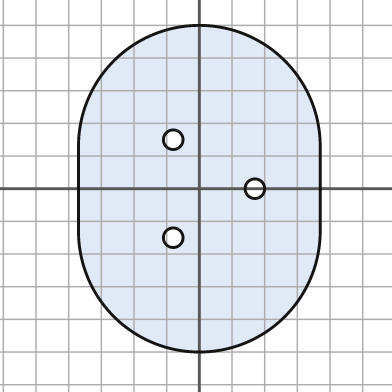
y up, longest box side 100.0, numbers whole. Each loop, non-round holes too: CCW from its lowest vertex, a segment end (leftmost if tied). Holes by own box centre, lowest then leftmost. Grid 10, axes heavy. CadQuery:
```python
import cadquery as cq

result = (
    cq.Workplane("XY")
    .moveTo(-37.0, -13.0)
    .threePointArc((0.0, -50.0), (37.0, -13.0))
    .lineTo(37.0, 13.0)
    .threePointArc((0.0, 50.0), (-37.0, 13.0))
    .close()
    .moveTo(-8.0, -15.0)
    .circle(3.0)
    .moveTo(17.0, 0.0)
    .circle(3.0)
    .moveTo(-8.0, 15.0)
    .circle(3.0)
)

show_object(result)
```